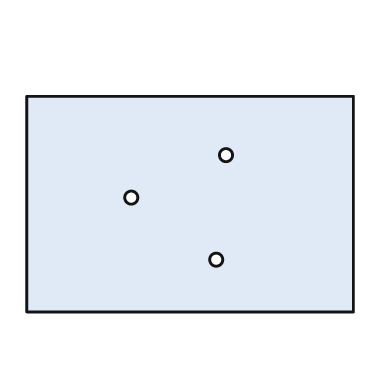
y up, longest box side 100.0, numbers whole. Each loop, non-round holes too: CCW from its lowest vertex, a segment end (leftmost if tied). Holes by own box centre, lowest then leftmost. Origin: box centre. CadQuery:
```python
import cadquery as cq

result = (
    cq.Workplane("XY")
    .moveTo(-50.0, -33.0)
    .lineTo(50.0, -33.0)
    .lineTo(50.0, 33.0)
    .lineTo(-50.0, 33.0)
    .close()
    .moveTo(8.0, -17.0)
    .circle(2.0)
    .moveTo(-18.0, 2.0)
    .circle(2.0)
    .moveTo(11.0, 15.0)
    .circle(2.0)
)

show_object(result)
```